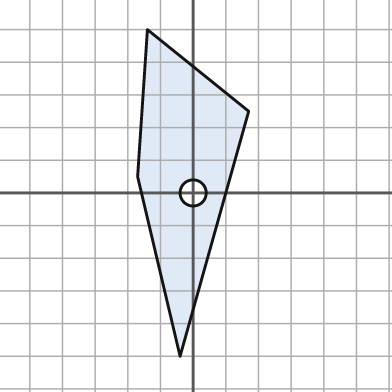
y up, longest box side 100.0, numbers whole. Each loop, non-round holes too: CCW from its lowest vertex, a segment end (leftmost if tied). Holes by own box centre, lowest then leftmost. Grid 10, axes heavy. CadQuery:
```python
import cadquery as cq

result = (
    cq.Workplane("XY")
    .moveTo(-4.0, -50.0)
    .lineTo(17.0, 25.0)
    .lineTo(-14.0, 50.0)
    .lineTo(-17.0, 5.0)
    .close()
    .moveTo(0.0, 0.0)
    .circle(4.0)
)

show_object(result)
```